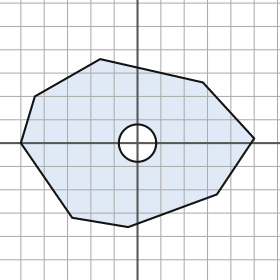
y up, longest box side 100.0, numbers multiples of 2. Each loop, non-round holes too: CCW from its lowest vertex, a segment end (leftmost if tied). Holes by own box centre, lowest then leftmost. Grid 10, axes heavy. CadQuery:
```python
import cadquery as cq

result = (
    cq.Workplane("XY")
    .moveTo(-4.0, -36.0)
    .lineTo(34.0, -22.0)
    .lineTo(50.0, 2.0)
    .lineTo(28.0, 26.0)
    .lineTo(-16.0, 36.0)
    .lineTo(-44.0, 20.0)
    .lineTo(-50.0, 0.0)
    .lineTo(-28.0, -32.0)
    .close()
    .moveTo(0.0, 0.0)
    .circle(8.0)
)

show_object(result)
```